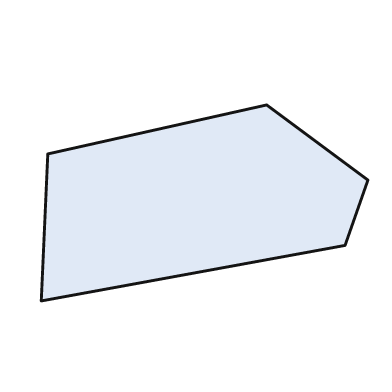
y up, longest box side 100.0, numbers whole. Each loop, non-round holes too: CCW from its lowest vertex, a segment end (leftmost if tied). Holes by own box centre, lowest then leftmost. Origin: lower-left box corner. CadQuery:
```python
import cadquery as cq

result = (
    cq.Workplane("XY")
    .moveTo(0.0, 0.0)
    .lineTo(93.0, 17.0)
    .lineTo(100.0, 37.0)
    .lineTo(69.0, 60.0)
    .lineTo(2.0, 45.0)
    .close()
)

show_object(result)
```